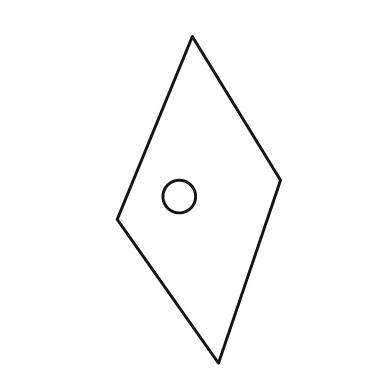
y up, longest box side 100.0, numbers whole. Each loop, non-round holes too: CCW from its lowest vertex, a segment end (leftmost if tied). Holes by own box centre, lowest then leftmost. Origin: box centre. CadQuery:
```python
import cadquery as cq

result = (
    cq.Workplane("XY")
    .moveTo(6.0, -50.0)
    .lineTo(25.0, 6.0)
    .lineTo(-2.0, 50.0)
    .lineTo(-25.0, -6.0)
    .close()
    .moveTo(-6.0, 1.0)
    .circle(5.0)
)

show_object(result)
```